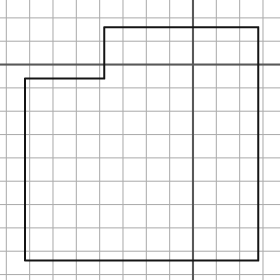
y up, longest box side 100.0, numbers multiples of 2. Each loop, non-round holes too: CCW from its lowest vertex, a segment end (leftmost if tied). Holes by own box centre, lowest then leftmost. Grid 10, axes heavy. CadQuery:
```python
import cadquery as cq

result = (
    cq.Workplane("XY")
    .moveTo(-72.0, -84.0)
    .lineTo(28.0, -84.0)
    .lineTo(28.0, 16.0)
    .lineTo(-38.0, 16.0)
    .lineTo(-38.0, -6.0)
    .lineTo(-72.0, -6.0)
    .close()
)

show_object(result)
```